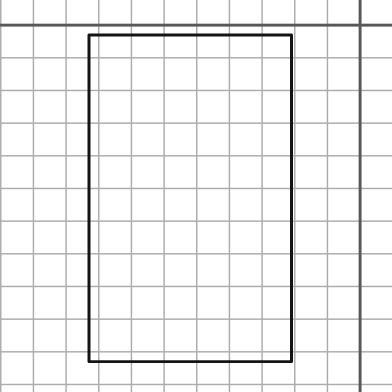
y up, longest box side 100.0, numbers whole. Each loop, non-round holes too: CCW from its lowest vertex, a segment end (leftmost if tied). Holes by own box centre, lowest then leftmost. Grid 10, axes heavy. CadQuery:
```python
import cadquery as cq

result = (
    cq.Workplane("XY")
    .moveTo(-83.0, -103.0)
    .lineTo(-21.0, -103.0)
    .lineTo(-21.0, -3.0)
    .lineTo(-83.0, -3.0)
    .close()
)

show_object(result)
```